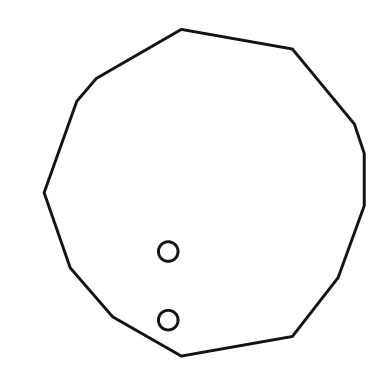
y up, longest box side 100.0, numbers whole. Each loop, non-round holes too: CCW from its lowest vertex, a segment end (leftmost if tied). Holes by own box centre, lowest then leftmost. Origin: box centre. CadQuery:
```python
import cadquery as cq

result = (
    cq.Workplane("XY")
    .moveTo(-7.0, -50.0)
    .lineTo(27.0, -44.0)
    .lineTo(41.0, -26.0)
    .lineTo(49.0, -4.0)
    .lineTo(49.0, 12.0)
    .lineTo(46.0, 21.0)
    .lineTo(27.0, 44.0)
    .lineTo(-7.0, 50.0)
    .lineTo(-33.0, 35.0)
    .lineTo(-39.0, 28.0)
    .lineTo(-49.0, 0.0)
    .lineTo(-41.0, -23.0)
    .lineTo(-28.0, -38.0)
    .close()
    .moveTo(-11.0, -39.0)
    .circle(3.0)
    .moveTo(-11.0, -18.0)
    .circle(3.0)
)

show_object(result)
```